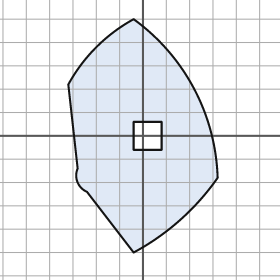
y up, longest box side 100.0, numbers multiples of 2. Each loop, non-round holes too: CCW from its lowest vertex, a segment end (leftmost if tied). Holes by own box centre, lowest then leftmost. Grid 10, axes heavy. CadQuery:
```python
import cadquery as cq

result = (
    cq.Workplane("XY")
    .moveTo(-4.0, -50.0)
    .threePointArc((16.0, -36.0), (32.0, -18.0))
    .threePointArc((22.0, 20.0), (-4.0, 50.0))
    .threePointArc((-20.0, 38.0), (-32.0, 22.0))
    .lineTo(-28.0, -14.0)
    .threePointArc((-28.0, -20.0), (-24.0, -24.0))
    .close()
    .moveTo(-4.0, -6.0)
    .lineTo(8.0, -6.0)
    .lineTo(8.0, 6.0)
    .lineTo(-4.0, 6.0)
    .close()
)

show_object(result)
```